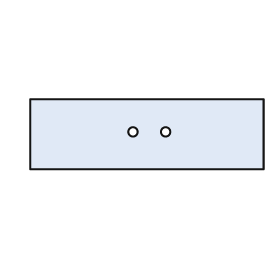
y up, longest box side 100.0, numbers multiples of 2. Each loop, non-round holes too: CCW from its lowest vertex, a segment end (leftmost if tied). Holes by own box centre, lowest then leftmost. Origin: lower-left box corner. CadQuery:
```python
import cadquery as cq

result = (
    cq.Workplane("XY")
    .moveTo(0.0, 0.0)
    .lineTo(100.0, 0.0)
    .lineTo(100.0, 30.0)
    .lineTo(0.0, 30.0)
    .close()
    .moveTo(44.0, 16.0)
    .circle(2.0)
    .moveTo(58.0, 16.0)
    .circle(2.0)
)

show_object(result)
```